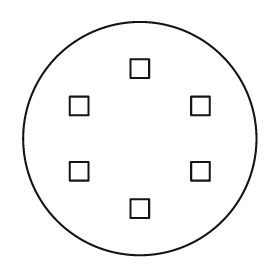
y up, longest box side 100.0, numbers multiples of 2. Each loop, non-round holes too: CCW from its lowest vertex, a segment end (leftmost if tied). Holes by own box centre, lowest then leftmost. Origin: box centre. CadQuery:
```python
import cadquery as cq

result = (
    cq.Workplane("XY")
    .moveTo(0.0, 0.0)
    .circle(50.0)
    .moveTo(-4.0, -34.0)
    .lineTo(4.0, -34.0)
    .lineTo(4.0, -26.0)
    .lineTo(-4.0, -26.0)
    .close()
    .moveTo(-30.0, -18.0)
    .lineTo(-22.0, -18.0)
    .lineTo(-22.0, -10.0)
    .lineTo(-30.0, -10.0)
    .close()
    .moveTo(22.0, -18.0)
    .lineTo(30.0, -18.0)
    .lineTo(30.0, -10.0)
    .lineTo(22.0, -10.0)
    .close()
    .moveTo(-30.0, 10.0)
    .lineTo(-22.0, 10.0)
    .lineTo(-22.0, 18.0)
    .lineTo(-30.0, 18.0)
    .close()
    .moveTo(22.0, 10.0)
    .lineTo(30.0, 10.0)
    .lineTo(30.0, 18.0)
    .lineTo(22.0, 18.0)
    .close()
    .moveTo(-4.0, 26.0)
    .lineTo(4.0, 26.0)
    .lineTo(4.0, 34.0)
    .lineTo(-4.0, 34.0)
    .close()
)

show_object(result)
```